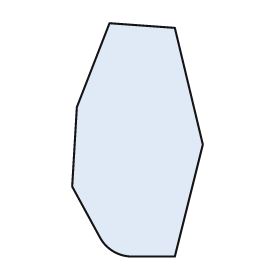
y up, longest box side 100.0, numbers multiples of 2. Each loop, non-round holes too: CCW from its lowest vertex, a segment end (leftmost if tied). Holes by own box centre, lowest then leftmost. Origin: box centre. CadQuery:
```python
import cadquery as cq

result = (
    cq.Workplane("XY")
    .moveTo(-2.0, -50.0)
    .lineTo(16.0, -50.0)
    .lineTo(28.0, -2.0)
    .lineTo(16.0, 48.0)
    .lineTo(-12.0, 50.0)
    .lineTo(-26.0, 14.0)
    .lineTo(-28.0, -20.0)
    .lineTo(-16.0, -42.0)
    .threePointArc((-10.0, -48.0), (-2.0, -50.0))
    .close()
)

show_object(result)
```